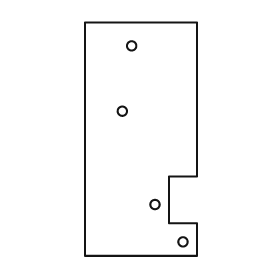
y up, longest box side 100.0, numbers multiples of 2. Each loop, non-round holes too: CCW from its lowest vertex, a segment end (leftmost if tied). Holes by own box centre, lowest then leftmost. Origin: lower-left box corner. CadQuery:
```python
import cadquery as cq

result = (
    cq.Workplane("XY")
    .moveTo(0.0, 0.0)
    .lineTo(48.0, 0.0)
    .lineTo(48.0, 14.0)
    .lineTo(36.0, 14.0)
    .lineTo(36.0, 34.0)
    .lineTo(48.0, 34.0)
    .lineTo(48.0, 100.0)
    .lineTo(0.0, 100.0)
    .close()
    .moveTo(42.0, 6.0)
    .circle(2.0)
    .moveTo(30.0, 22.0)
    .circle(2.0)
    .moveTo(16.0, 62.0)
    .circle(2.0)
    .moveTo(20.0, 90.0)
    .circle(2.0)
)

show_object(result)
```